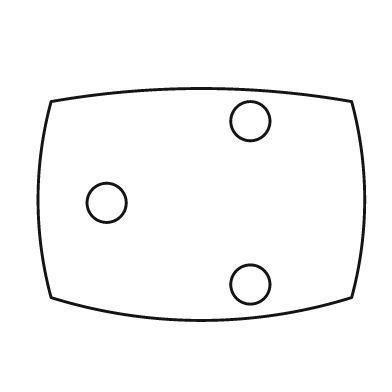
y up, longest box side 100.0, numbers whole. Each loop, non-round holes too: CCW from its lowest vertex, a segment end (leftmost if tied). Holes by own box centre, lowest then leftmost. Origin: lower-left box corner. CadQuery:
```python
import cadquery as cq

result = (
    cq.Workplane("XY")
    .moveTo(4.0, 7.0)
    .threePointArc((50.0, 0.0), (96.0, 7.0))
    .threePointArc((100.0, 37.0), (96.0, 67.0))
    .threePointArc((50.0, 71.0), (4.0, 67.0))
    .threePointArc((0.0, 37.0), (4.0, 7.0))
    .close()
    .moveTo(65.0, 11.0)
    .circle(6.0)
    .moveTo(21.0, 36.0)
    .circle(6.0)
    .moveTo(65.0, 61.0)
    .circle(6.0)
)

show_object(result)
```